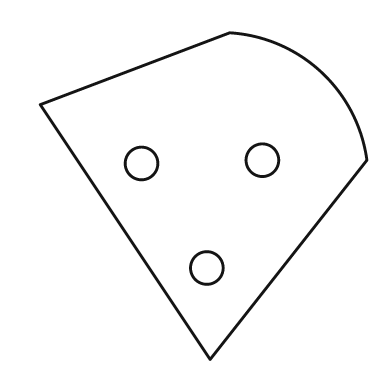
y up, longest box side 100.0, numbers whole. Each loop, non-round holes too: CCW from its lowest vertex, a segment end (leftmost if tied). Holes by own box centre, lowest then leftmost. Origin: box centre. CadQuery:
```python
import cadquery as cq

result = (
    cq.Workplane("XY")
    .moveTo(2.0, -50.0)
    .lineTo(50.0, 11.0)
    .threePointArc((36.0, 38.0), (8.0, 50.0))
    .lineTo(-50.0, 28.0)
    .close()
    .moveTo(1.0, -22.0)
    .circle(5.0)
    .moveTo(-19.0, 10.0)
    .circle(5.0)
    .moveTo(18.0, 11.0)
    .circle(5.0)
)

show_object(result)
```